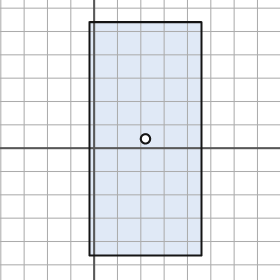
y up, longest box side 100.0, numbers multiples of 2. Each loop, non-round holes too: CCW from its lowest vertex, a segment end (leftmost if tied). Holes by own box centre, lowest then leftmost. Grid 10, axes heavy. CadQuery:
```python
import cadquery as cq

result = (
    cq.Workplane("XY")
    .moveTo(-2.0, -46.0)
    .lineTo(46.0, -46.0)
    .lineTo(46.0, 54.0)
    .lineTo(-2.0, 54.0)
    .close()
    .moveTo(22.0, 4.0)
    .circle(2.0)
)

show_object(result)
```